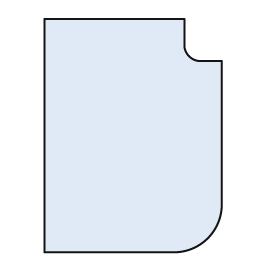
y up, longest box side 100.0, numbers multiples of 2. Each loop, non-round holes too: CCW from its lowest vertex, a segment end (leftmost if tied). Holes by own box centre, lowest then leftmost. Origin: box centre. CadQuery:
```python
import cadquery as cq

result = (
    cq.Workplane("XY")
    .moveTo(-38.0, -50.0)
    .lineTo(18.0, -50.0)
    .threePointArc((32.0, -44.0), (38.0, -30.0))
    .lineTo(38.0, 32.0)
    .lineTo(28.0, 32.0)
    .threePointArc((24.0, 34.0), (22.0, 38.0))
    .lineTo(22.0, 50.0)
    .lineTo(-38.0, 50.0)
    .close()
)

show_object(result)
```